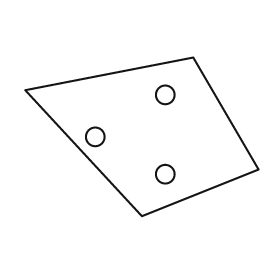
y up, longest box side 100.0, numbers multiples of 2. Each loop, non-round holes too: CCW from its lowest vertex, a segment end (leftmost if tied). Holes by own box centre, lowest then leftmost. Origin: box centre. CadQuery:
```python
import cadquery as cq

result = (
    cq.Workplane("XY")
    .moveTo(0.0, -34.0)
    .lineTo(50.0, -14.0)
    .lineTo(22.0, 34.0)
    .lineTo(-50.0, 20.0)
    .close()
    .moveTo(10.0, -16.0)
    .circle(4.0)
    .moveTo(-20.0, 0.0)
    .circle(4.0)
    .moveTo(10.0, 18.0)
    .circle(4.0)
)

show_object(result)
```